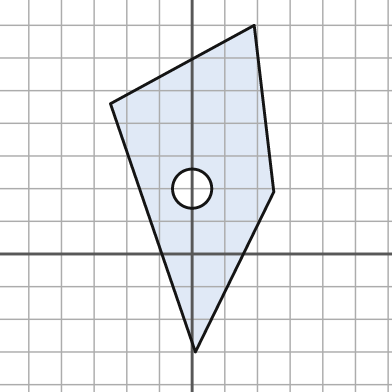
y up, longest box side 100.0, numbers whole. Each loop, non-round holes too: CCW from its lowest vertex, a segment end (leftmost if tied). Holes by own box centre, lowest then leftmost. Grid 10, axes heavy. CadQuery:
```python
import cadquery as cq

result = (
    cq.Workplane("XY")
    .moveTo(1.0, -30.0)
    .lineTo(25.0, 19.0)
    .lineTo(19.0, 70.0)
    .lineTo(-25.0, 46.0)
    .close()
    .moveTo(0.0, 20.0)
    .circle(6.0)
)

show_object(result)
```